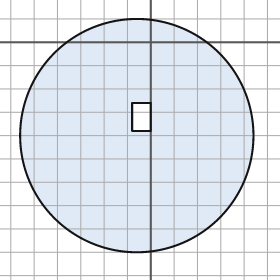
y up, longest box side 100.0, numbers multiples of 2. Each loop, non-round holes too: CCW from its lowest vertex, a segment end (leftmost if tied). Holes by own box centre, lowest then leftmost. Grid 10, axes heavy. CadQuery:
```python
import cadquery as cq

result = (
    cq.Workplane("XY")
    .moveTo(-6.0, -40.0)
    .circle(50.0)
    .moveTo(-8.0, -38.0)
    .lineTo(0.0, -38.0)
    .lineTo(0.0, -26.0)
    .lineTo(-8.0, -26.0)
    .close()
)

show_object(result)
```